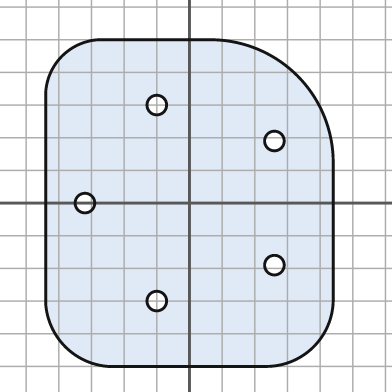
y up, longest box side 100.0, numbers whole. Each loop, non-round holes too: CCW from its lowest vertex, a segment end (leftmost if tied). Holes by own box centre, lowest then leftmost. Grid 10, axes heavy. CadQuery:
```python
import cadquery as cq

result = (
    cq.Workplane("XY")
    .moveTo(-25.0, -50.0)
    .lineTo(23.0, -50.0)
    .threePointArc((38.0, -44.0), (44.0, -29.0))
    .lineTo(44.0, 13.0)
    .threePointArc((33.0, 39.0), (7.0, 50.0))
    .lineTo(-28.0, 50.0)
    .threePointArc((-39.0, 45.0), (-44.0, 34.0))
    .lineTo(-44.0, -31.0)
    .threePointArc((-38.0, -44.0), (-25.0, -50.0))
    .close()
    .moveTo(-10.0, -30.0)
    .circle(3.0)
    .moveTo(26.0, -19.0)
    .circle(3.0)
    .moveTo(-32.0, 0.0)
    .circle(3.0)
    .moveTo(26.0, 19.0)
    .circle(3.0)
    .moveTo(-10.0, 30.0)
    .circle(3.0)
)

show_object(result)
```